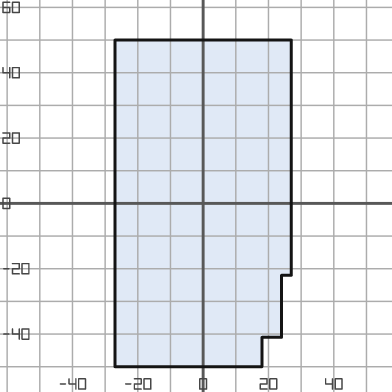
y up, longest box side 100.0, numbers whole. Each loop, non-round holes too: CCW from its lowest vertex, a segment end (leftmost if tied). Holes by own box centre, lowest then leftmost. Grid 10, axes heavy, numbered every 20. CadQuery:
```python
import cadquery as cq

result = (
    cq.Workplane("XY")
    .moveTo(-27.0, -50.0)
    .lineTo(18.0, -50.0)
    .lineTo(18.0, -41.0)
    .lineTo(24.0, -41.0)
    .lineTo(24.0, -22.0)
    .lineTo(27.0, -22.0)
    .lineTo(27.0, 50.0)
    .lineTo(-27.0, 50.0)
    .close()
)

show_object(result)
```